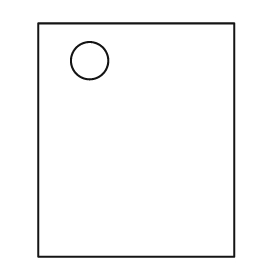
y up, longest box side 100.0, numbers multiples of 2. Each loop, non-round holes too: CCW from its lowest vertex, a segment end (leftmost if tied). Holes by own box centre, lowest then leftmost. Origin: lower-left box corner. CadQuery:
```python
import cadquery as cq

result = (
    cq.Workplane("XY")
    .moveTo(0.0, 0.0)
    .lineTo(84.0, 0.0)
    .lineTo(84.0, 100.0)
    .lineTo(0.0, 100.0)
    .close()
    .moveTo(22.0, 84.0)
    .circle(8.0)
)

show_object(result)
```